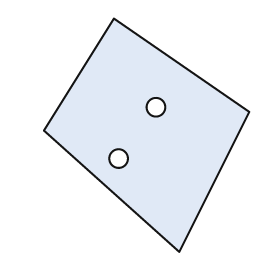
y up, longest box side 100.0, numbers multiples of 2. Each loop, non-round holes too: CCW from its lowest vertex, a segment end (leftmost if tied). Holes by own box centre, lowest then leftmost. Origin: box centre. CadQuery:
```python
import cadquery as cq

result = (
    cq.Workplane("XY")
    .moveTo(14.0, -50.0)
    .lineTo(44.0, 10.0)
    .lineTo(-14.0, 50.0)
    .lineTo(-44.0, 2.0)
    .close()
    .moveTo(-12.0, -10.0)
    .circle(4.0)
    .moveTo(4.0, 12.0)
    .circle(4.0)
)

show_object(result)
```